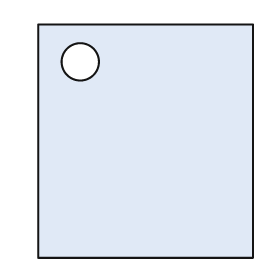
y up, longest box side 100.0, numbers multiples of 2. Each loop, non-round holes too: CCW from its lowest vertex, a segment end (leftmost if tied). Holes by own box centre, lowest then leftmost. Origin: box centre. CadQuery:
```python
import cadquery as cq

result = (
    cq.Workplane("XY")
    .moveTo(-46.0, -50.0)
    .lineTo(46.0, -50.0)
    .lineTo(46.0, 50.0)
    .lineTo(-46.0, 50.0)
    .close()
    .moveTo(-28.0, 34.0)
    .circle(8.0)
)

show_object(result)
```